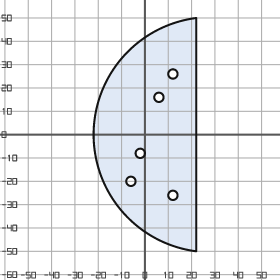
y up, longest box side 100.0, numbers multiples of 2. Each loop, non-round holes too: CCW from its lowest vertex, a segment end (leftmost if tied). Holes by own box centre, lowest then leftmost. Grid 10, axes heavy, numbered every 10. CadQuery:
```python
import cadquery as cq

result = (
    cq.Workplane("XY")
    .moveTo(22.0, -50.0)
    .lineTo(22.0, 50.0)
    .threePointArc((-22.0, 0.0), (22.0, -50.0))
    .close()
    .moveTo(12.0, -26.0)
    .circle(2.0)
    .moveTo(-6.0, -20.0)
    .circle(2.0)
    .moveTo(-2.0, -8.0)
    .circle(2.0)
    .moveTo(6.0, 16.0)
    .circle(2.0)
    .moveTo(12.0, 26.0)
    .circle(2.0)
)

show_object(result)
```